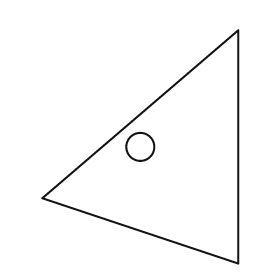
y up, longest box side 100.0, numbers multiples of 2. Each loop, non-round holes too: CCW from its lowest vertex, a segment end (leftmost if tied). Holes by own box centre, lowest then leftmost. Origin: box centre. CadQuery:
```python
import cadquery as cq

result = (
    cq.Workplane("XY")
    .moveTo(42.0, -50.0)
    .lineTo(42.0, 50.0)
    .lineTo(-42.0, -22.0)
    .close()
    .moveTo(0.0, 0.0)
    .circle(6.0)
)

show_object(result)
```